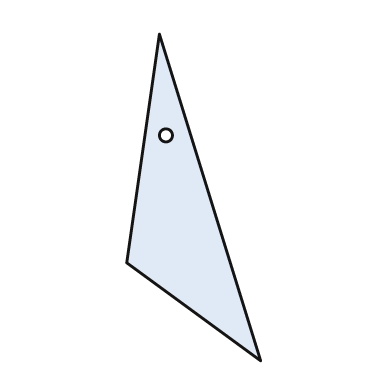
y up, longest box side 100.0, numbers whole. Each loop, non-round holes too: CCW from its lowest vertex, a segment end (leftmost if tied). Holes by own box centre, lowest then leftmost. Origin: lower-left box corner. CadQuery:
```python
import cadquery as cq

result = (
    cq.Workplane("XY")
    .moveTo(41.0, 0.0)
    .lineTo(10.0, 100.0)
    .lineTo(0.0, 30.0)
    .close()
    .moveTo(12.0, 69.0)
    .circle(2.0)
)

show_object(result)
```